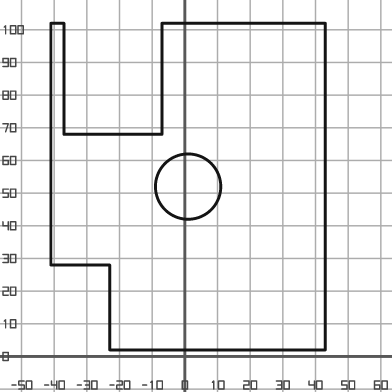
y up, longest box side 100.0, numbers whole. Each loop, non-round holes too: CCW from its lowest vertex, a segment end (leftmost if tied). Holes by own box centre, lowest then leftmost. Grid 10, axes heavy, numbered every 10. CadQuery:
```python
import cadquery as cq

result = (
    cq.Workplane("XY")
    .moveTo(-23.0, 2.0)
    .lineTo(43.0, 2.0)
    .lineTo(43.0, 102.0)
    .lineTo(-7.0, 102.0)
    .lineTo(-7.0, 68.0)
    .lineTo(-37.0, 68.0)
    .lineTo(-37.0, 102.0)
    .lineTo(-41.0, 102.0)
    .lineTo(-41.0, 28.0)
    .lineTo(-23.0, 28.0)
    .close()
    .moveTo(1.0, 52.0)
    .circle(10.0)
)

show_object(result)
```